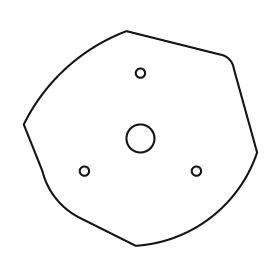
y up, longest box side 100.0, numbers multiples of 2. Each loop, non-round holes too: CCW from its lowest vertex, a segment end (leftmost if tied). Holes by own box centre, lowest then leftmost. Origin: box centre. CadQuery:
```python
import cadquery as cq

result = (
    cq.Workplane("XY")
    .moveTo(-2.0, -46.0)
    .threePointArc((30.0, -34.0), (50.0, -6.0))
    .lineTo(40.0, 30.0)
    .threePointArc((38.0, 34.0), (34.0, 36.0))
    .lineTo(-6.0, 46.0)
    .threePointArc((-32.0, 30.0), (-50.0, 6.0))
    .lineTo(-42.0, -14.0)
    .threePointArc((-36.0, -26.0), (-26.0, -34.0))
    .close()
    .moveTo(-24.0, -14.0)
    .circle(2.0)
    .moveTo(24.0, -14.0)
    .circle(2.0)
    .moveTo(0.0, 0.0)
    .circle(6.0)
    .moveTo(0.0, 28.0)
    .circle(2.0)
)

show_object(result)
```